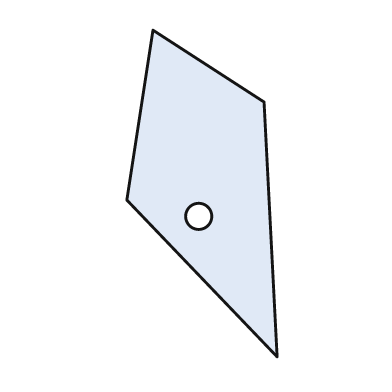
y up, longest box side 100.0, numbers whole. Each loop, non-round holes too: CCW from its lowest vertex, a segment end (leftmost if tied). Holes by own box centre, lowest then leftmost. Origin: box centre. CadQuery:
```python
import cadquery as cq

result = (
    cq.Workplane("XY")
    .moveTo(23.0, -50.0)
    .lineTo(19.0, 28.0)
    .lineTo(-15.0, 50.0)
    .lineTo(-23.0, -2.0)
    .close()
    .moveTo(-1.0, -7.0)
    .circle(4.0)
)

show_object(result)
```